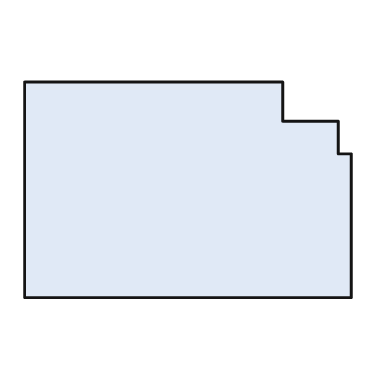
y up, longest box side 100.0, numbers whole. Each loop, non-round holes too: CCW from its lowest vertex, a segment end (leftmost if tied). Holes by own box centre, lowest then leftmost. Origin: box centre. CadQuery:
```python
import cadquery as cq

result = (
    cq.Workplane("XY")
    .moveTo(-50.0, -33.0)
    .lineTo(50.0, -33.0)
    .lineTo(50.0, 11.0)
    .lineTo(46.0, 11.0)
    .lineTo(46.0, 21.0)
    .lineTo(29.0, 21.0)
    .lineTo(29.0, 33.0)
    .lineTo(-50.0, 33.0)
    .close()
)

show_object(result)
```